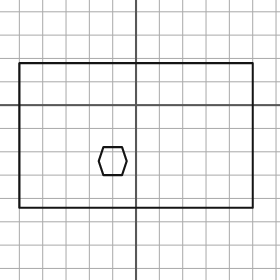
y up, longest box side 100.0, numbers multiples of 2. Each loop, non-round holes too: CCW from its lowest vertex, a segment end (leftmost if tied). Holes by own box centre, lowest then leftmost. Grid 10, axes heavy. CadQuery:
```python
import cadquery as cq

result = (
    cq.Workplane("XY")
    .moveTo(-50.0, -44.0)
    .lineTo(50.0, -44.0)
    .lineTo(50.0, 18.0)
    .lineTo(-50.0, 18.0)
    .close()
    .moveTo(-14.0, -30.0)
    .lineTo(-6.0, -30.0)
    .lineTo(-4.0, -24.0)
    .lineTo(-6.0, -18.0)
    .lineTo(-14.0, -18.0)
    .lineTo(-16.0, -24.0)
    .close()
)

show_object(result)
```